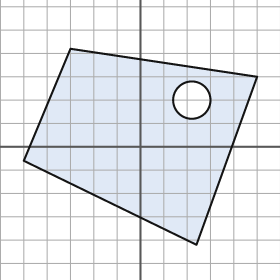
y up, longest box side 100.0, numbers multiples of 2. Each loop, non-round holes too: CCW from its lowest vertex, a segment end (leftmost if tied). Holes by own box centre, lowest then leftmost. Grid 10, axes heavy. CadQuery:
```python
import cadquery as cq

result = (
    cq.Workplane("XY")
    .moveTo(24.0, -42.0)
    .lineTo(50.0, 30.0)
    .lineTo(-30.0, 42.0)
    .lineTo(-50.0, -6.0)
    .close()
    .moveTo(22.0, 20.0)
    .circle(8.0)
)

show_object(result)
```